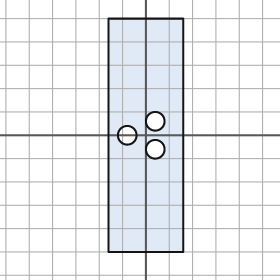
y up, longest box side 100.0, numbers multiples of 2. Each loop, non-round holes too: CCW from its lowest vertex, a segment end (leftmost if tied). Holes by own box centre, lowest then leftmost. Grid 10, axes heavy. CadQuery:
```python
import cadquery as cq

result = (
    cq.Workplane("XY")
    .moveTo(-16.0, -50.0)
    .lineTo(16.0, -50.0)
    .lineTo(16.0, 50.0)
    .lineTo(-16.0, 50.0)
    .close()
    .moveTo(4.0, -6.0)
    .circle(4.0)
    .moveTo(-8.0, 0.0)
    .circle(4.0)
    .moveTo(4.0, 6.0)
    .circle(4.0)
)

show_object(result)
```